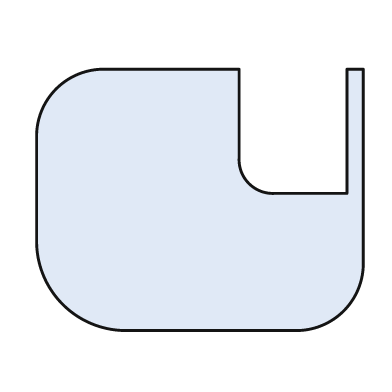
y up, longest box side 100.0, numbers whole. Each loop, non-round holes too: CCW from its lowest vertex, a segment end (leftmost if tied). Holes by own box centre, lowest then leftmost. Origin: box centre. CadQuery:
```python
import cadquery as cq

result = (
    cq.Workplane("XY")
    .moveTo(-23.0, -40.0)
    .lineTo(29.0, -40.0)
    .threePointArc((44.0, -34.0), (50.0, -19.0))
    .lineTo(50.0, 40.0)
    .lineTo(45.0, 40.0)
    .lineTo(45.0, 2.0)
    .lineTo(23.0, 2.0)
    .threePointArc((15.0, 5.0), (12.0, 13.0))
    .lineTo(12.0, 40.0)
    .lineTo(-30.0, 40.0)
    .threePointArc((-44.0, 34.0), (-50.0, 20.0))
    .lineTo(-50.0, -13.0)
    .threePointArc((-42.0, -32.0), (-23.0, -40.0))
    .close()
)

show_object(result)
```